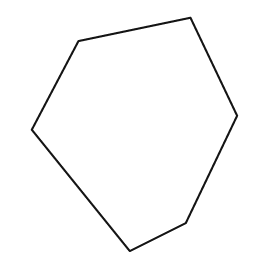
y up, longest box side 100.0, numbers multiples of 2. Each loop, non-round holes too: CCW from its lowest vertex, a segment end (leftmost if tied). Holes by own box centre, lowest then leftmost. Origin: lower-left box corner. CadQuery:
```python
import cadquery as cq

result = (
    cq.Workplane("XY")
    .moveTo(42.0, 0.0)
    .lineTo(66.0, 12.0)
    .lineTo(88.0, 58.0)
    .lineTo(68.0, 100.0)
    .lineTo(20.0, 90.0)
    .lineTo(0.0, 52.0)
    .close()
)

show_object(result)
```